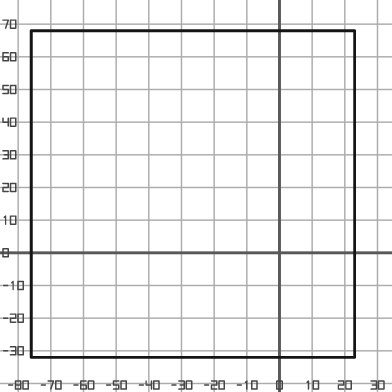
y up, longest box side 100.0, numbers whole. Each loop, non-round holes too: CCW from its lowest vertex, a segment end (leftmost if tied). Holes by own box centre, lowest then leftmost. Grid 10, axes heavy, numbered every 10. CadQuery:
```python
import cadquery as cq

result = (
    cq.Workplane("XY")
    .moveTo(-76.0, -32.0)
    .lineTo(23.0, -32.0)
    .lineTo(23.0, 68.0)
    .lineTo(-76.0, 68.0)
    .close()
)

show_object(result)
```